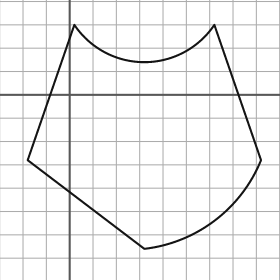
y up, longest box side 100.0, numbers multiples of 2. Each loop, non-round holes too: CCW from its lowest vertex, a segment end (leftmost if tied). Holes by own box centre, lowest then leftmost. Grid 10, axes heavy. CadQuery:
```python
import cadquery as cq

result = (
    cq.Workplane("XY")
    .moveTo(32.0, -66.0)
    .threePointArc((62.0, -54.0), (82.0, -28.0))
    .lineTo(62.0, 30.0)
    .threePointArc((32.0, 14.0), (2.0, 30.0))
    .lineTo(-18.0, -28.0)
    .close()
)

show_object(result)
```